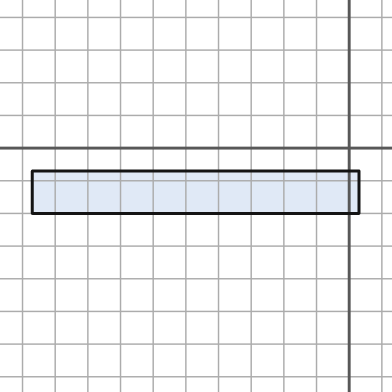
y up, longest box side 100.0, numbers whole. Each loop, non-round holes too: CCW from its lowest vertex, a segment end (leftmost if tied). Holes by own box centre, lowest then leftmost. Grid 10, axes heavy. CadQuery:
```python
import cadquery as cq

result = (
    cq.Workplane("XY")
    .moveTo(-97.0, -20.0)
    .lineTo(3.0, -20.0)
    .lineTo(3.0, -7.0)
    .lineTo(-97.0, -7.0)
    .close()
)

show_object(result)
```